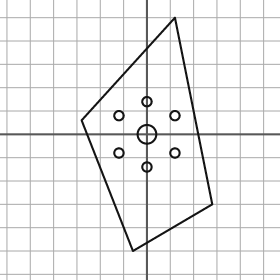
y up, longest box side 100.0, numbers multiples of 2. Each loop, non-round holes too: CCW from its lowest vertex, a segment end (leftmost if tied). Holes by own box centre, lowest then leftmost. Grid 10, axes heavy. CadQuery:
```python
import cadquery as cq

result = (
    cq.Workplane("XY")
    .moveTo(-6.0, -50.0)
    .lineTo(28.0, -30.0)
    .lineTo(12.0, 50.0)
    .lineTo(-28.0, 6.0)
    .close()
    .moveTo(0.0, -14.0)
    .circle(2.0)
    .moveTo(-12.0, -8.0)
    .circle(2.0)
    .moveTo(12.0, -8.0)
    .circle(2.0)
    .moveTo(0.0, 0.0)
    .circle(4.0)
    .moveTo(-12.0, 8.0)
    .circle(2.0)
    .moveTo(12.0, 8.0)
    .circle(2.0)
    .moveTo(0.0, 14.0)
    .circle(2.0)
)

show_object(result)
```